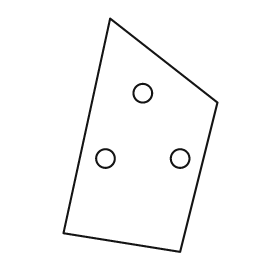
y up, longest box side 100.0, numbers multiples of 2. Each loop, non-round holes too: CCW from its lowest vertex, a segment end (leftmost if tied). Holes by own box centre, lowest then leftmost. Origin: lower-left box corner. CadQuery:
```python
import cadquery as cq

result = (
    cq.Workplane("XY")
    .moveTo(50.0, 0.0)
    .lineTo(66.0, 64.0)
    .lineTo(20.0, 100.0)
    .lineTo(0.0, 8.0)
    .close()
    .moveTo(18.0, 40.0)
    .circle(4.0)
    .moveTo(50.0, 40.0)
    .circle(4.0)
    .moveTo(34.0, 68.0)
    .circle(4.0)
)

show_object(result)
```